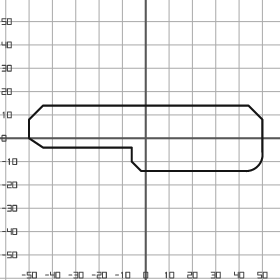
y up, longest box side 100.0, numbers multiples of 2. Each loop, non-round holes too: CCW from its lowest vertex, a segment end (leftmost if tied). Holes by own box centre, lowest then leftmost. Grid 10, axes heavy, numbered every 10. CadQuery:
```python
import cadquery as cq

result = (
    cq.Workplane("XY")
    .moveTo(-2.0, -14.0)
    .lineTo(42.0, -14.0)
    .threePointArc((48.0, -12.0), (50.0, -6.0))
    .lineTo(50.0, 8.0)
    .lineTo(44.0, 14.0)
    .lineTo(-44.0, 14.0)
    .lineTo(-50.0, 8.0)
    .lineTo(-50.0, 0.0)
    .lineTo(-44.0, -4.0)
    .lineTo(-6.0, -4.0)
    .lineTo(-6.0, -10.0)
    .close()
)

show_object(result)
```